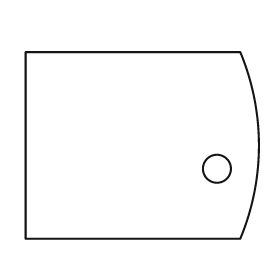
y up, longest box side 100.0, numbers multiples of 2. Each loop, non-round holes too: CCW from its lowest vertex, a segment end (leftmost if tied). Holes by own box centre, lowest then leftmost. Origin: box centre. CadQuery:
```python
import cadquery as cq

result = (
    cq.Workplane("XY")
    .moveTo(-50.0, -40.0)
    .lineTo(42.0, -40.0)
    .threePointArc((50.0, 0.0), (42.0, 40.0))
    .lineTo(-50.0, 40.0)
    .close()
    .moveTo(32.0, -10.0)
    .circle(6.0)
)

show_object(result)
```